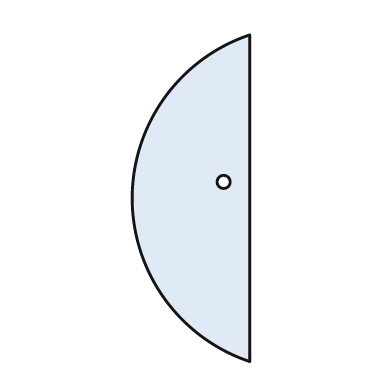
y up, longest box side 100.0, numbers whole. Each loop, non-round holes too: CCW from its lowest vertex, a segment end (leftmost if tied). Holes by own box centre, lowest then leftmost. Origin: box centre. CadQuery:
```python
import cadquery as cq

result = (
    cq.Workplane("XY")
    .moveTo(18.0, -50.0)
    .lineTo(18.0, 50.0)
    .threePointArc((-18.0, 0.0), (18.0, -50.0))
    .close()
    .moveTo(10.0, 5.0)
    .circle(2.0)
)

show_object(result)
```